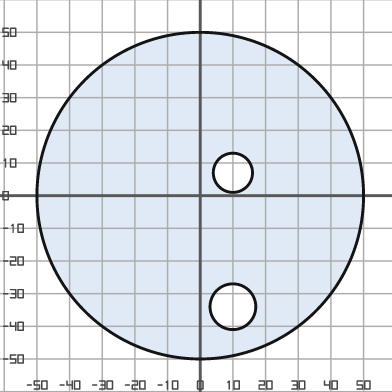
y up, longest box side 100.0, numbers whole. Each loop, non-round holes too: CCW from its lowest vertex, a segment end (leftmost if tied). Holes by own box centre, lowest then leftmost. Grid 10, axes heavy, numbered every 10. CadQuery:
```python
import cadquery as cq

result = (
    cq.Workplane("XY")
    .moveTo(0.0, 0.0)
    .circle(50.0)
    .moveTo(10.0, -34.0)
    .circle(7.0)
    .moveTo(10.0, 7.0)
    .circle(6.0)
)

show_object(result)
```